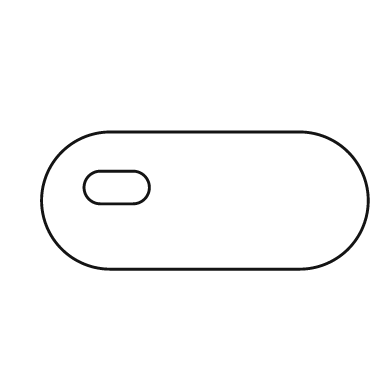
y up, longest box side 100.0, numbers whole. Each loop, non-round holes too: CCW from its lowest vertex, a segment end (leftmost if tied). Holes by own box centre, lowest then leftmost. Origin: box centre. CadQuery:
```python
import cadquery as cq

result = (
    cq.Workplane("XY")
    .moveTo(-29.0, -21.0)
    .lineTo(29.0, -21.0)
    .threePointArc((50.0, 0.0), (29.0, 21.0))
    .lineTo(-29.0, 21.0)
    .threePointArc((-50.0, 0.0), (-29.0, -21.0))
    .close()
    .moveTo(-32.0, -1.0)
    .lineTo(-22.0, -1.0)
    .threePointArc((-17.0, 4.0), (-22.0, 9.0))
    .lineTo(-32.0, 9.0)
    .threePointArc((-37.0, 4.0), (-32.0, -1.0))
    .close()
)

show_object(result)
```